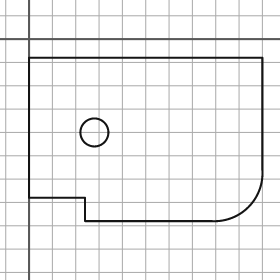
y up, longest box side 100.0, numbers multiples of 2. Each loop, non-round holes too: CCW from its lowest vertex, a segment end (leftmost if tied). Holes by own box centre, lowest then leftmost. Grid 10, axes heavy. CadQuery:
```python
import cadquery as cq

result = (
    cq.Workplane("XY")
    .moveTo(24.0, -78.0)
    .lineTo(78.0, -78.0)
    .threePointArc((94.0, -72.0), (100.0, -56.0))
    .lineTo(100.0, -8.0)
    .lineTo(0.0, -8.0)
    .lineTo(0.0, -68.0)
    .lineTo(24.0, -68.0)
    .close()
    .moveTo(28.0, -40.0)
    .circle(6.0)
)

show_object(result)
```